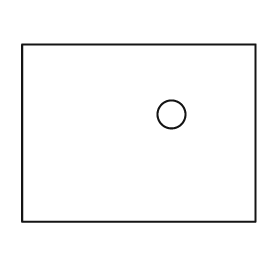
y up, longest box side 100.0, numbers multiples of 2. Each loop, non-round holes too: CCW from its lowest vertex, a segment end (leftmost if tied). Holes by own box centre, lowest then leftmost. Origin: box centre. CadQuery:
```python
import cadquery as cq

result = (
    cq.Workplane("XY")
    .moveTo(-50.0, -38.0)
    .lineTo(50.0, -38.0)
    .lineTo(50.0, 38.0)
    .lineTo(-50.0, 38.0)
    .close()
    .moveTo(14.0, 8.0)
    .circle(6.0)
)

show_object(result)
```